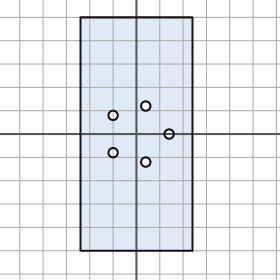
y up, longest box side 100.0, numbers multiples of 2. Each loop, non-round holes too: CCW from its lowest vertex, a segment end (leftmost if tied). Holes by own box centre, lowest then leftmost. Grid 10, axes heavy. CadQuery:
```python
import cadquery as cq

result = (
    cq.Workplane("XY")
    .moveTo(-24.0, -50.0)
    .lineTo(24.0, -50.0)
    .lineTo(24.0, 50.0)
    .lineTo(-24.0, 50.0)
    .close()
    .moveTo(4.0, -12.0)
    .circle(2.0)
    .moveTo(-10.0, -8.0)
    .circle(2.0)
    .moveTo(14.0, 0.0)
    .circle(2.0)
    .moveTo(-10.0, 8.0)
    .circle(2.0)
    .moveTo(4.0, 12.0)
    .circle(2.0)
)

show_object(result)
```